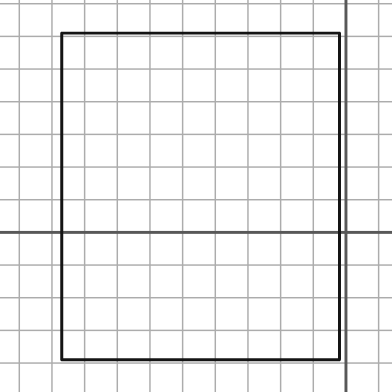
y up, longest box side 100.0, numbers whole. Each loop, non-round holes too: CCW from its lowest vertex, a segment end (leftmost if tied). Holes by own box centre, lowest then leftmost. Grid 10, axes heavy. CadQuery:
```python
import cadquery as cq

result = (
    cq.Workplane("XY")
    .moveTo(-87.0, -39.0)
    .lineTo(-2.0, -39.0)
    .lineTo(-2.0, 61.0)
    .lineTo(-87.0, 61.0)
    .close()
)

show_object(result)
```